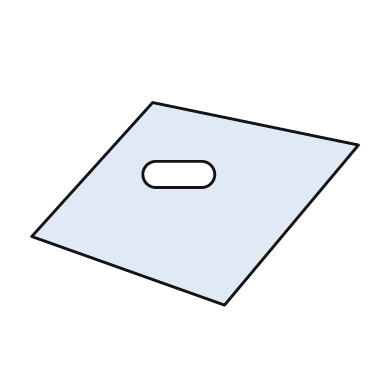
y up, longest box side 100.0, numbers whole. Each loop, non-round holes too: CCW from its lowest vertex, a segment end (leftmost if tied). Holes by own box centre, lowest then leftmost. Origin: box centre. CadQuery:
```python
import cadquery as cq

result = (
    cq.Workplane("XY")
    .moveTo(9.0, -31.0)
    .lineTo(50.0, 18.0)
    .lineTo(-13.0, 31.0)
    .lineTo(-50.0, -10.0)
    .close()
    .moveTo(-12.0, 5.0)
    .lineTo(2.0, 5.0)
    .threePointArc((6.0, 9.0), (2.0, 13.0))
    .lineTo(-12.0, 13.0)
    .threePointArc((-16.0, 9.0), (-12.0, 5.0))
    .close()
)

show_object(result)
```